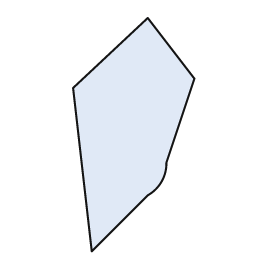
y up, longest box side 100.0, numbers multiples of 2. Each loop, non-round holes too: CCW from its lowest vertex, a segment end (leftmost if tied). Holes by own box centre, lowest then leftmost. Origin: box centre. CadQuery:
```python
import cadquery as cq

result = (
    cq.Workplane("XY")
    .moveTo(-18.0, -50.0)
    .lineTo(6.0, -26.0)
    .threePointArc((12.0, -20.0), (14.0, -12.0))
    .lineTo(26.0, 24.0)
    .lineTo(6.0, 50.0)
    .lineTo(-26.0, 20.0)
    .close()
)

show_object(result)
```